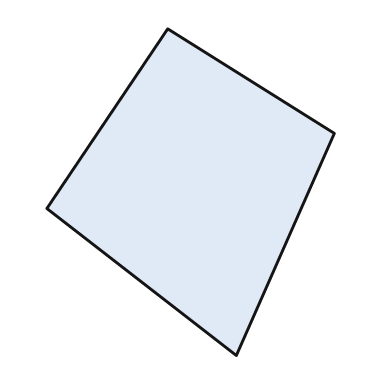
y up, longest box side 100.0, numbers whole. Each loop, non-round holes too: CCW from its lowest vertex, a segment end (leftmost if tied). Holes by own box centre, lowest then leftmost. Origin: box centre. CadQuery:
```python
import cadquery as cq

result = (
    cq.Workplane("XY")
    .moveTo(14.0, -50.0)
    .lineTo(44.0, 18.0)
    .lineTo(-7.0, 50.0)
    .lineTo(-44.0, -5.0)
    .close()
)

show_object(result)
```